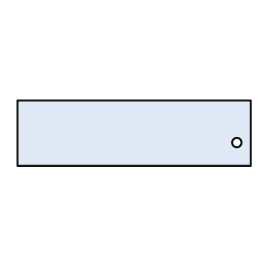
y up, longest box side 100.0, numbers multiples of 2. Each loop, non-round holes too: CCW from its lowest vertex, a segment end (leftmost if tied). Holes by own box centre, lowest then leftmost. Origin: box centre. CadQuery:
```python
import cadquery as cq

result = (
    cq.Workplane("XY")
    .moveTo(-50.0, -14.0)
    .lineTo(50.0, -14.0)
    .lineTo(50.0, 14.0)
    .lineTo(-50.0, 14.0)
    .close()
    .moveTo(44.0, -4.0)
    .circle(2.0)
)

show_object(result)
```